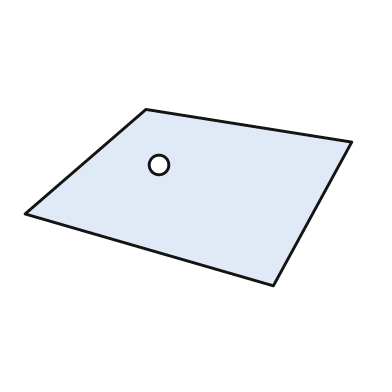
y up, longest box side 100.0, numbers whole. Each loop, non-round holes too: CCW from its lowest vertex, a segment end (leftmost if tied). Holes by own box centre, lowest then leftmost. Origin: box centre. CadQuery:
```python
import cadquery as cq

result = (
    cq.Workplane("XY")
    .moveTo(26.0, -27.0)
    .lineTo(50.0, 17.0)
    .lineTo(-13.0, 27.0)
    .lineTo(-50.0, -5.0)
    .close()
    .moveTo(-9.0, 10.0)
    .circle(3.0)
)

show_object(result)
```